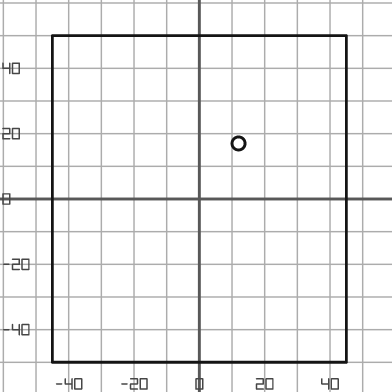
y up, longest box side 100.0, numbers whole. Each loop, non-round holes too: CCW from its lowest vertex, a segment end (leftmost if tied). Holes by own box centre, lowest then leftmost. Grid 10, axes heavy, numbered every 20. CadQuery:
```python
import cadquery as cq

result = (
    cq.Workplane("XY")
    .moveTo(-45.0, -50.0)
    .lineTo(45.0, -50.0)
    .lineTo(45.0, 50.0)
    .lineTo(-45.0, 50.0)
    .close()
    .moveTo(12.0, 17.0)
    .circle(2.0)
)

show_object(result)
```